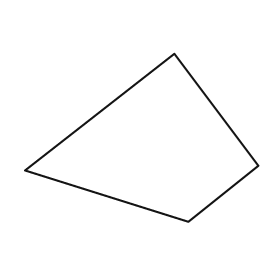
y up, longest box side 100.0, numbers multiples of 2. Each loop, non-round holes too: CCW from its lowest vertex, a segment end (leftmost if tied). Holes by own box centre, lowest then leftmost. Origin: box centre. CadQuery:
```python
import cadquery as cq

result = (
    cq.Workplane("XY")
    .moveTo(20.0, -36.0)
    .lineTo(50.0, -12.0)
    .lineTo(14.0, 36.0)
    .lineTo(-50.0, -14.0)
    .close()
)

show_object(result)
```